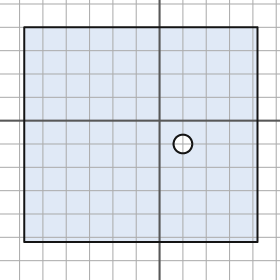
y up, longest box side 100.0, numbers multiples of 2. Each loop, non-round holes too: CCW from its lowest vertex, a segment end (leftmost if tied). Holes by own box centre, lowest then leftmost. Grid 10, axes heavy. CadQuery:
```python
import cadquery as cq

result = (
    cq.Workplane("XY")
    .moveTo(-58.0, -52.0)
    .lineTo(42.0, -52.0)
    .lineTo(42.0, 40.0)
    .lineTo(-58.0, 40.0)
    .close()
    .moveTo(10.0, -10.0)
    .circle(4.0)
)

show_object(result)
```